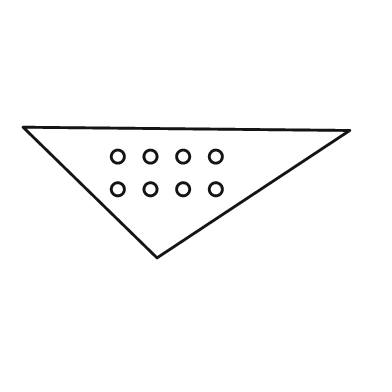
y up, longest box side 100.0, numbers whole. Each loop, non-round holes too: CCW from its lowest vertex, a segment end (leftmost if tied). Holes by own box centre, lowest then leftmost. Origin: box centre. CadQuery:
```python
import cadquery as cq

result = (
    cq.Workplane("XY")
    .moveTo(-9.0, -20.0)
    .lineTo(50.0, 19.0)
    .lineTo(-50.0, 20.0)
    .close()
    .moveTo(-21.0, 1.0)
    .circle(2.0)
    .moveTo(-11.0, 1.0)
    .circle(2.0)
    .moveTo(-1.0, 1.0)
    .circle(2.0)
    .moveTo(9.0, 1.0)
    .circle(2.0)
    .moveTo(-21.0, 11.0)
    .circle(2.0)
    .moveTo(-11.0, 11.0)
    .circle(2.0)
    .moveTo(-1.0, 11.0)
    .circle(2.0)
    .moveTo(9.0, 11.0)
    .circle(2.0)
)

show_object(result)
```